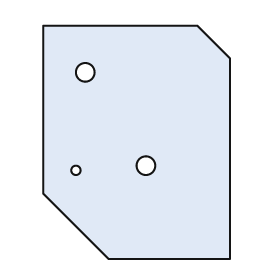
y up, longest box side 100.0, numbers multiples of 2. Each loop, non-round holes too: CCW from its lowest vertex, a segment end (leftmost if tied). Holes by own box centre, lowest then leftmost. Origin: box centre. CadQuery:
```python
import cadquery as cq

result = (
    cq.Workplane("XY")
    .moveTo(-12.0, -50.0)
    .lineTo(40.0, -50.0)
    .lineTo(40.0, 36.0)
    .lineTo(26.0, 50.0)
    .lineTo(-40.0, 50.0)
    .lineTo(-40.0, -22.0)
    .close()
    .moveTo(-26.0, -12.0)
    .circle(2.0)
    .moveTo(4.0, -10.0)
    .circle(4.0)
    .moveTo(-22.0, 30.0)
    .circle(4.0)
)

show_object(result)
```